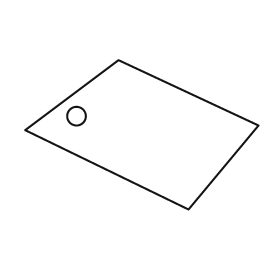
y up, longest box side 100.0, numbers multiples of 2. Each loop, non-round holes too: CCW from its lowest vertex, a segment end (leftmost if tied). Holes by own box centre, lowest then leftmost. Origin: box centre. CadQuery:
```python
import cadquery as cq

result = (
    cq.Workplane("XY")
    .moveTo(20.0, -32.0)
    .lineTo(50.0, 4.0)
    .lineTo(-10.0, 32.0)
    .lineTo(-50.0, 2.0)
    .close()
    .moveTo(-28.0, 8.0)
    .circle(4.0)
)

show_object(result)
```